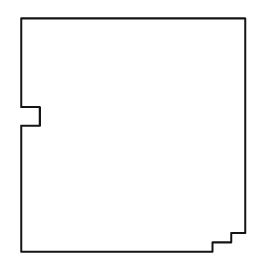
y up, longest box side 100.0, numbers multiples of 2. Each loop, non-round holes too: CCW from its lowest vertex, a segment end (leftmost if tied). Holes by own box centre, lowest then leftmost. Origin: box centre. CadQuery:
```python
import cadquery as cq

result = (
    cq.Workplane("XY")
    .moveTo(-48.0, -50.0)
    .lineTo(34.0, -50.0)
    .lineTo(34.0, -46.0)
    .lineTo(42.0, -46.0)
    .lineTo(42.0, -42.0)
    .lineTo(48.0, -42.0)
    .lineTo(48.0, 50.0)
    .lineTo(-48.0, 50.0)
    .lineTo(-48.0, 12.0)
    .lineTo(-40.0, 12.0)
    .lineTo(-40.0, 4.0)
    .lineTo(-48.0, 4.0)
    .close()
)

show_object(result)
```